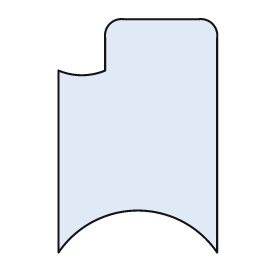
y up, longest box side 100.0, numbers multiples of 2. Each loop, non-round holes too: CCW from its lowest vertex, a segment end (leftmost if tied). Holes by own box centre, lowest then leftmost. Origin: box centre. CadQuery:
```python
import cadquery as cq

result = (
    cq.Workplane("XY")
    .moveTo(-34.0, -50.0)
    .threePointArc((0.0, -32.0), (34.0, -50.0))
    .lineTo(34.0, 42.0)
    .threePointArc((32.0, 48.0), (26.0, 50.0))
    .lineTo(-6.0, 50.0)
    .threePointArc((-12.0, 48.0), (-14.0, 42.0))
    .lineTo(-14.0, 28.0)
    .threePointArc((-24.0, 26.0), (-34.0, 28.0))
    .close()
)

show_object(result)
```